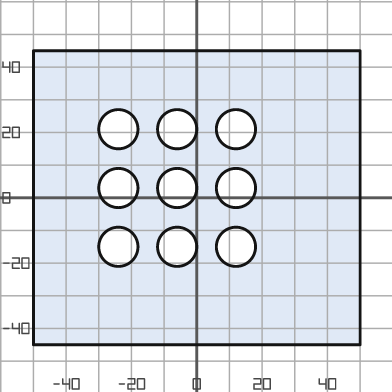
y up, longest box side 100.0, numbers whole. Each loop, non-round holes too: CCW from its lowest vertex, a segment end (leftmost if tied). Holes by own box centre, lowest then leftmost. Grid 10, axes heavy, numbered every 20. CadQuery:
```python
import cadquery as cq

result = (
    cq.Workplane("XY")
    .moveTo(-50.0, -45.0)
    .lineTo(50.0, -45.0)
    .lineTo(50.0, 45.0)
    .lineTo(-50.0, 45.0)
    .close()
    .moveTo(-24.0, -15.0)
    .circle(6.0)
    .moveTo(-6.0, -15.0)
    .circle(6.0)
    .moveTo(12.0, -15.0)
    .circle(6.0)
    .moveTo(-24.0, 3.0)
    .circle(6.0)
    .moveTo(-6.0, 3.0)
    .circle(6.0)
    .moveTo(12.0, 3.0)
    .circle(6.0)
    .moveTo(-24.0, 21.0)
    .circle(6.0)
    .moveTo(-6.0, 21.0)
    .circle(6.0)
    .moveTo(12.0, 21.0)
    .circle(6.0)
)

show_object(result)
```